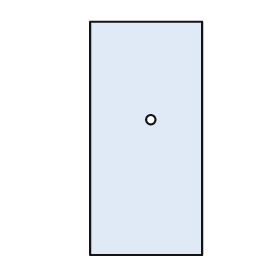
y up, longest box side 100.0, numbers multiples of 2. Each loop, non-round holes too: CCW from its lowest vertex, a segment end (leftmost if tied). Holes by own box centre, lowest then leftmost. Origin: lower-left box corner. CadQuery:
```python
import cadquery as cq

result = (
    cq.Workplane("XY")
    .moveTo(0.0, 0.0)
    .lineTo(48.0, 0.0)
    .lineTo(48.0, 100.0)
    .lineTo(0.0, 100.0)
    .close()
    .moveTo(26.0, 58.0)
    .circle(2.0)
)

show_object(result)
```